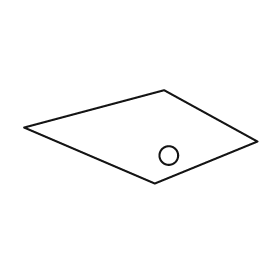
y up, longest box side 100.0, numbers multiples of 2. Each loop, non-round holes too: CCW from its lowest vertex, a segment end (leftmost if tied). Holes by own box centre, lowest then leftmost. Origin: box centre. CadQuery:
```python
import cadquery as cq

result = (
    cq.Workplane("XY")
    .moveTo(6.0, -20.0)
    .lineTo(50.0, -2.0)
    .lineTo(10.0, 20.0)
    .lineTo(-50.0, 4.0)
    .close()
    .moveTo(12.0, -8.0)
    .circle(4.0)
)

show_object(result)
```